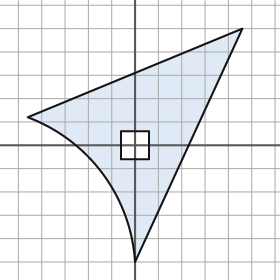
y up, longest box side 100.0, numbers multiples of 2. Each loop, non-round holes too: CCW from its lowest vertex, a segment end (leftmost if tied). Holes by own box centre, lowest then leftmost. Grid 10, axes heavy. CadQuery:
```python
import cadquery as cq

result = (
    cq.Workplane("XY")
    .moveTo(0.0, -50.0)
    .lineTo(46.0, 50.0)
    .lineTo(-46.0, 12.0)
    .threePointArc((-14.0, -12.0), (0.0, -50.0))
    .close()
    .moveTo(-6.0, -6.0)
    .lineTo(6.0, -6.0)
    .lineTo(6.0, 6.0)
    .lineTo(-6.0, 6.0)
    .close()
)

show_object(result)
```